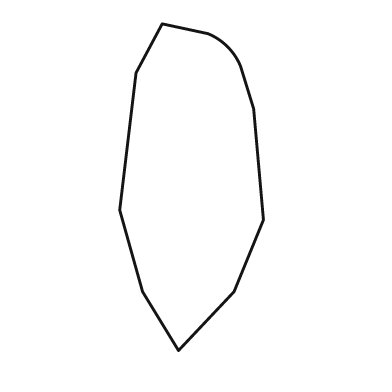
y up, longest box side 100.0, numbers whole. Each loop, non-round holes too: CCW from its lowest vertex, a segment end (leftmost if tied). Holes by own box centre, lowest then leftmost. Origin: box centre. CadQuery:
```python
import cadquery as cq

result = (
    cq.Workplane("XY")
    .moveTo(-4.0, -50.0)
    .lineTo(13.0, -32.0)
    .lineTo(22.0, -10.0)
    .lineTo(19.0, 24.0)
    .lineTo(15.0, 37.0)
    .threePointArc((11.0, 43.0), (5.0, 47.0))
    .lineTo(-9.0, 50.0)
    .lineTo(-17.0, 35.0)
    .lineTo(-22.0, -7.0)
    .lineTo(-15.0, -32.0)
    .close()
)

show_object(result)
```